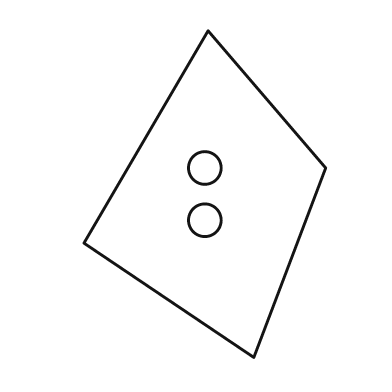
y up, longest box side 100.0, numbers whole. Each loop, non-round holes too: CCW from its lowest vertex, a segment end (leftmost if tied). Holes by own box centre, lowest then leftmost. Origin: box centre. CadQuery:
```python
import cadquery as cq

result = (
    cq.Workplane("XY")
    .moveTo(15.0, -50.0)
    .lineTo(37.0, 8.0)
    .lineTo(1.0, 50.0)
    .lineTo(-37.0, -15.0)
    .close()
    .moveTo(0.0, -8.0)
    .circle(5.0)
    .moveTo(0.0, 8.0)
    .circle(5.0)
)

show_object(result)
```